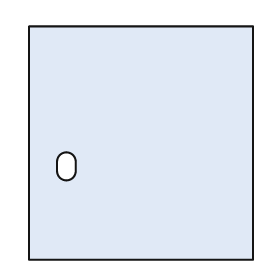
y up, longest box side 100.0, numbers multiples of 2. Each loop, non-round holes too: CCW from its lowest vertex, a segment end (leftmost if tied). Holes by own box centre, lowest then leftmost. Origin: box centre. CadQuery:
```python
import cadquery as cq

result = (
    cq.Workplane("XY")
    .moveTo(-48.0, -50.0)
    .lineTo(48.0, -50.0)
    .lineTo(48.0, 50.0)
    .lineTo(-48.0, 50.0)
    .close()
    .moveTo(-36.0, -12.0)
    .threePointArc((-32.0, -16.0), (-28.0, -12.0))
    .lineTo(-28.0, -8.0)
    .threePointArc((-32.0, -4.0), (-36.0, -8.0))
    .close()
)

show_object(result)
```